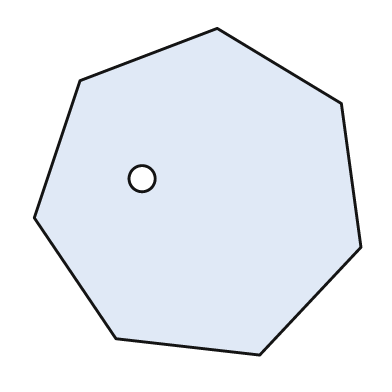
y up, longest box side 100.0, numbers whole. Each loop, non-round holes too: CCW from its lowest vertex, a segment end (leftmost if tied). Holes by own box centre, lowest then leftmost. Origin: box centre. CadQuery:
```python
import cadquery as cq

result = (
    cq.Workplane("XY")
    .moveTo(19.0, -50.0)
    .lineTo(50.0, -17.0)
    .lineTo(44.0, 27.0)
    .lineTo(6.0, 50.0)
    .lineTo(-36.0, 34.0)
    .lineTo(-50.0, -8.0)
    .lineTo(-25.0, -45.0)
    .close()
    .moveTo(-17.0, 4.0)
    .circle(4.0)
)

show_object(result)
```